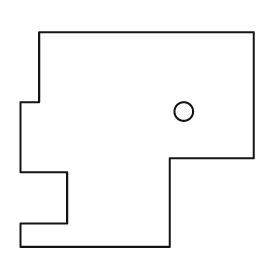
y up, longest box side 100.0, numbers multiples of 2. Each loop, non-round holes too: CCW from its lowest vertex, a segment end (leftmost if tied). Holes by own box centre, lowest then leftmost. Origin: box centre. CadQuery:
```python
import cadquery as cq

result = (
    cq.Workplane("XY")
    .moveTo(-50.0, -46.0)
    .lineTo(14.0, -46.0)
    .lineTo(14.0, -8.0)
    .lineTo(50.0, -8.0)
    .lineTo(50.0, 46.0)
    .lineTo(-42.0, 46.0)
    .lineTo(-42.0, 16.0)
    .lineTo(-50.0, 16.0)
    .lineTo(-50.0, -14.0)
    .lineTo(-30.0, -14.0)
    .lineTo(-30.0, -36.0)
    .lineTo(-50.0, -36.0)
    .close()
    .moveTo(20.0, 12.0)
    .circle(4.0)
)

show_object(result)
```